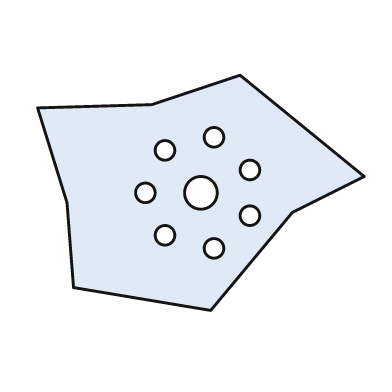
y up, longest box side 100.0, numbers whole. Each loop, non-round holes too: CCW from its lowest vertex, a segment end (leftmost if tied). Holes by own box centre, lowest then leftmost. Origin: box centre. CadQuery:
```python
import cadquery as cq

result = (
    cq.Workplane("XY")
    .moveTo(3.0, -36.0)
    .lineTo(28.0, -6.0)
    .lineTo(50.0, 5.0)
    .lineTo(12.0, 36.0)
    .lineTo(-15.0, 27.0)
    .lineTo(-50.0, 26.0)
    .lineTo(-41.0, -3.0)
    .lineTo(-39.0, -29.0)
    .close()
    .moveTo(4.0, -17.0)
    .circle(3.0)
    .moveTo(-11.0, -13.0)
    .circle(3.0)
    .moveTo(15.0, -7.0)
    .circle(3.0)
    .moveTo(-17.0, 0.0)
    .circle(3.0)
    .moveTo(0.0, 0.0)
    .circle(5.0)
    .moveTo(15.0, 7.0)
    .circle(3.0)
    .moveTo(-11.0, 13.0)
    .circle(3.0)
    .moveTo(4.0, 17.0)
    .circle(3.0)
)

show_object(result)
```